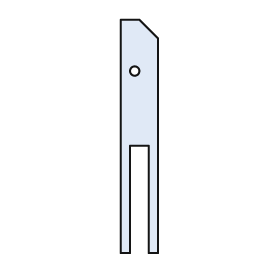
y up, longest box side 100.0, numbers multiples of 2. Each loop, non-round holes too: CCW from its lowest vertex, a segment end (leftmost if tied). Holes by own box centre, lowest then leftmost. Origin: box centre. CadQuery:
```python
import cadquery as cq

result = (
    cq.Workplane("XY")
    .moveTo(-8.0, -50.0)
    .lineTo(-4.0, -50.0)
    .lineTo(-4.0, -4.0)
    .lineTo(4.0, -4.0)
    .lineTo(4.0, -50.0)
    .lineTo(8.0, -50.0)
    .lineTo(8.0, 42.0)
    .lineTo(0.0, 50.0)
    .lineTo(-8.0, 50.0)
    .close()
    .moveTo(-2.0, 28.0)
    .circle(2.0)
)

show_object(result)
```